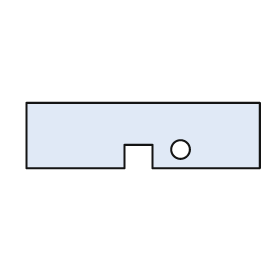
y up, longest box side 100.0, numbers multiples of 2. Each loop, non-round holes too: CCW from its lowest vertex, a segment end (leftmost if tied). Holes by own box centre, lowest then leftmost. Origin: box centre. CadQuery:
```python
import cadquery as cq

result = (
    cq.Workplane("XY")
    .moveTo(-50.0, -14.0)
    .lineTo(-8.0, -14.0)
    .lineTo(-8.0, -4.0)
    .lineTo(4.0, -4.0)
    .lineTo(4.0, -14.0)
    .lineTo(50.0, -14.0)
    .lineTo(50.0, 14.0)
    .lineTo(-50.0, 14.0)
    .close()
    .moveTo(16.0, -6.0)
    .circle(4.0)
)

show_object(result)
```